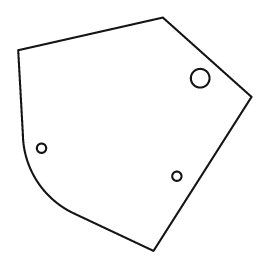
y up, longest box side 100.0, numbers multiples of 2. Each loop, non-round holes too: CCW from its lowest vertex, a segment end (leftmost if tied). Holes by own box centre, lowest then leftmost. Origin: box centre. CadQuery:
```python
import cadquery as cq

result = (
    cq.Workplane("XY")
    .moveTo(8.0, -50.0)
    .lineTo(50.0, 16.0)
    .lineTo(12.0, 50.0)
    .lineTo(-50.0, 36.0)
    .lineTo(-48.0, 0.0)
    .threePointArc((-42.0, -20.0), (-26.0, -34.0))
    .close()
    .moveTo(18.0, -18.0)
    .circle(2.0)
    .moveTo(-40.0, -6.0)
    .circle(2.0)
    .moveTo(28.0, 24.0)
    .circle(4.0)
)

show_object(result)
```